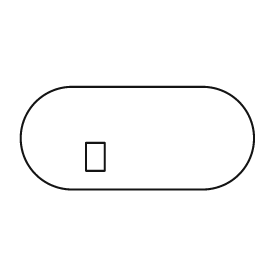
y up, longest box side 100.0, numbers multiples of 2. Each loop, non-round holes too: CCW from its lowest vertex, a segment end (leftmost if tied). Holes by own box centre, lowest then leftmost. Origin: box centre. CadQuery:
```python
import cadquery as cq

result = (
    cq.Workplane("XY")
    .moveTo(-28.0, -22.0)
    .lineTo(28.0, -22.0)
    .threePointArc((50.0, 0.0), (28.0, 22.0))
    .lineTo(-28.0, 22.0)
    .threePointArc((-50.0, 0.0), (-28.0, -22.0))
    .close()
    .moveTo(-22.0, -14.0)
    .lineTo(-14.0, -14.0)
    .lineTo(-14.0, -2.0)
    .lineTo(-22.0, -2.0)
    .close()
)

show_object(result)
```